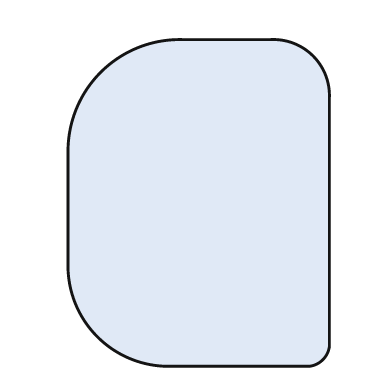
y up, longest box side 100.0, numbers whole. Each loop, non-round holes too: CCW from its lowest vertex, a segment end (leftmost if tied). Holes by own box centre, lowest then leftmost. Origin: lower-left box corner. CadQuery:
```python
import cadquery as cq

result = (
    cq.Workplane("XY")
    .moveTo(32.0, 0.0)
    .lineTo(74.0, 0.0)
    .threePointArc((78.0, 2.0), (80.0, 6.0))
    .lineTo(80.0, 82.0)
    .threePointArc((75.0, 95.0), (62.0, 100.0))
    .lineTo(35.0, 100.0)
    .threePointArc((10.0, 90.0), (0.0, 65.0))
    .lineTo(0.0, 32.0)
    .threePointArc((9.0, 9.0), (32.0, 0.0))
    .close()
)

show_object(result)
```